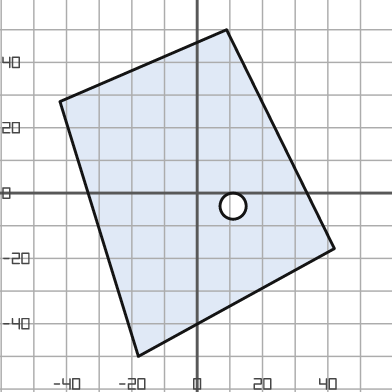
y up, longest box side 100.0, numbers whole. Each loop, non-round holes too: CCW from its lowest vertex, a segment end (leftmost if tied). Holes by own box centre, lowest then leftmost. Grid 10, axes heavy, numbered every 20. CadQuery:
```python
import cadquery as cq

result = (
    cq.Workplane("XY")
    .moveTo(-18.0, -50.0)
    .lineTo(42.0, -17.0)
    .lineTo(9.0, 50.0)
    .lineTo(-42.0, 28.0)
    .close()
    .moveTo(11.0, -4.0)
    .circle(4.0)
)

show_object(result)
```